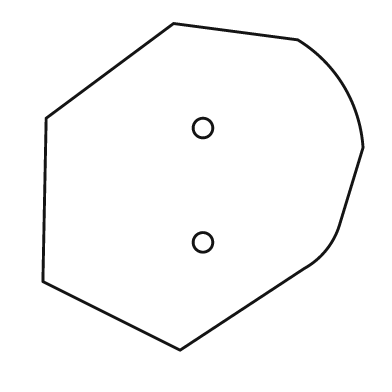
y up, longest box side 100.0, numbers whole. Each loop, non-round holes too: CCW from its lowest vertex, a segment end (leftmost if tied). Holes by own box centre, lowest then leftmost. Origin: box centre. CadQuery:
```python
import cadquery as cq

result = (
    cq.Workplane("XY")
    .moveTo(-7.0, -50.0)
    .lineTo(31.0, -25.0)
    .threePointArc((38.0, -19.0), (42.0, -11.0))
    .lineTo(49.0, 12.0)
    .threePointArc((43.0, 31.0), (29.0, 45.0))
    .lineTo(-9.0, 50.0)
    .lineTo(-48.0, 21.0)
    .lineTo(-49.0, -29.0)
    .close()
    .moveTo(0.0, -17.0)
    .circle(3.0)
    .moveTo(0.0, 18.0)
    .circle(3.0)
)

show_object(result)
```